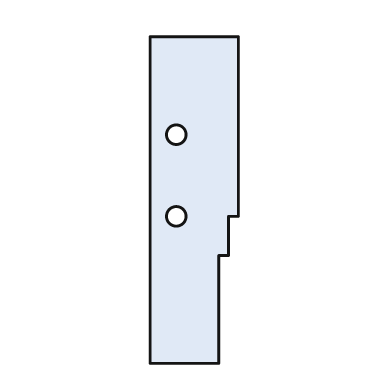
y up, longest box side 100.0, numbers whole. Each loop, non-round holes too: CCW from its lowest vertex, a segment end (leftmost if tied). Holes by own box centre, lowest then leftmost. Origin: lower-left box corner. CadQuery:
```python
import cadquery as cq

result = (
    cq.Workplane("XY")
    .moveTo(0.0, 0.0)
    .lineTo(21.0, 0.0)
    .lineTo(21.0, 33.0)
    .lineTo(24.0, 33.0)
    .lineTo(24.0, 45.0)
    .lineTo(27.0, 45.0)
    .lineTo(27.0, 100.0)
    .lineTo(0.0, 100.0)
    .close()
    .moveTo(8.0, 45.0)
    .circle(3.0)
    .moveTo(8.0, 70.0)
    .circle(3.0)
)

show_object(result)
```